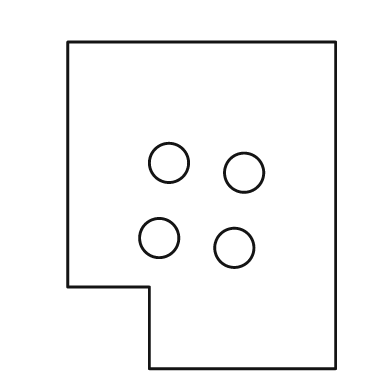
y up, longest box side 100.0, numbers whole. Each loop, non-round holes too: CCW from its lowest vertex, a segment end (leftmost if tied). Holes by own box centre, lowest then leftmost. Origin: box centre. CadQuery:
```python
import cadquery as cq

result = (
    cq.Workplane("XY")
    .moveTo(-16.0, -50.0)
    .lineTo(41.0, -50.0)
    .lineTo(41.0, 50.0)
    .lineTo(-41.0, 50.0)
    .lineTo(-41.0, -25.0)
    .lineTo(-16.0, -25.0)
    .close()
    .moveTo(10.0, -13.0)
    .circle(6.0)
    .moveTo(-13.0, -10.0)
    .circle(6.0)
    .moveTo(13.0, 10.0)
    .circle(6.0)
    .moveTo(-10.0, 13.0)
    .circle(6.0)
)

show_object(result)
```